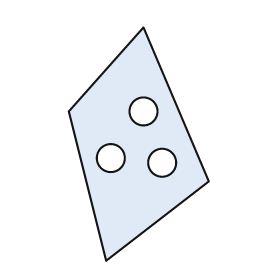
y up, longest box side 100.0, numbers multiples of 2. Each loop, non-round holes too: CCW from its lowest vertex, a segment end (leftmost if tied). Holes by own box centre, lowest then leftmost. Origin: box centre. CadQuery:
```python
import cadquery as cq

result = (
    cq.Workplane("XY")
    .moveTo(-14.0, -50.0)
    .lineTo(30.0, -16.0)
    .lineTo(2.0, 50.0)
    .lineTo(-30.0, 14.0)
    .close()
    .moveTo(10.0, -8.0)
    .circle(6.0)
    .moveTo(-12.0, -6.0)
    .circle(6.0)
    .moveTo(2.0, 14.0)
    .circle(6.0)
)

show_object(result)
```